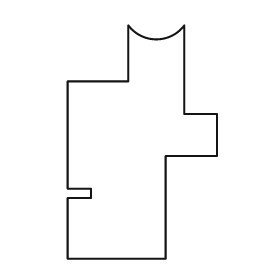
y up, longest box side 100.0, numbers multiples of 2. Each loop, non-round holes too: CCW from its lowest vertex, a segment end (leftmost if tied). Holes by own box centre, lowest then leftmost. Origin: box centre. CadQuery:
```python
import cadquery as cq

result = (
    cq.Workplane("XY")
    .moveTo(-32.0, -50.0)
    .lineTo(10.0, -50.0)
    .lineTo(10.0, -6.0)
    .lineTo(32.0, -6.0)
    .lineTo(32.0, 12.0)
    .lineTo(18.0, 12.0)
    .lineTo(18.0, 50.0)
    .threePointArc((6.0, 44.0), (-6.0, 50.0))
    .lineTo(-6.0, 26.0)
    .lineTo(-32.0, 26.0)
    .lineTo(-32.0, -20.0)
    .lineTo(-22.0, -20.0)
    .lineTo(-22.0, -24.0)
    .lineTo(-32.0, -24.0)
    .close()
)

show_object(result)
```